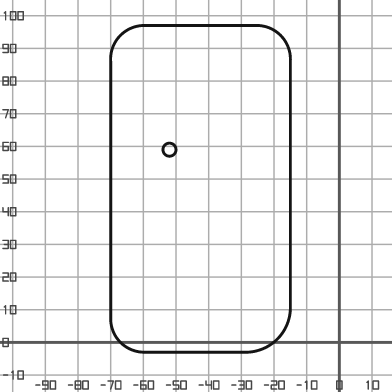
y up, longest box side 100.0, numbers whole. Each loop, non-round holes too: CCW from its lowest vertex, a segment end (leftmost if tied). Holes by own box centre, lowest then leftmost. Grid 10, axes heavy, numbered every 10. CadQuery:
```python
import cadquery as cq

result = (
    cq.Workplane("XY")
    .moveTo(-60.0, -3.0)
    .lineTo(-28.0, -3.0)
    .threePointArc((-19.0, 1.0), (-15.0, 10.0))
    .lineTo(-15.0, 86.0)
    .threePointArc((-18.0, 94.0), (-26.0, 97.0))
    .lineTo(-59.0, 97.0)
    .threePointArc((-67.0, 94.0), (-70.0, 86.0))
    .lineTo(-70.0, 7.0)
    .threePointArc((-67.0, 0.0), (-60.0, -3.0))
    .close()
    .moveTo(-52.0, 59.0)
    .circle(2.0)
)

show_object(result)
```